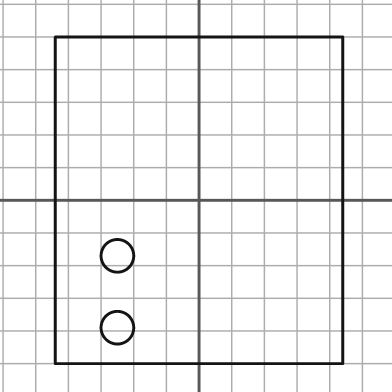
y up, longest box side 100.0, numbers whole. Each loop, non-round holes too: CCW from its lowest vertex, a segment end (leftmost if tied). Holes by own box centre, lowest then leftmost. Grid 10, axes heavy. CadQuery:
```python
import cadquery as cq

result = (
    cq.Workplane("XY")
    .moveTo(-44.0, -50.0)
    .lineTo(44.0, -50.0)
    .lineTo(44.0, 50.0)
    .lineTo(-44.0, 50.0)
    .close()
    .moveTo(-25.0, -39.0)
    .circle(5.0)
    .moveTo(-25.0, -17.0)
    .circle(5.0)
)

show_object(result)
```